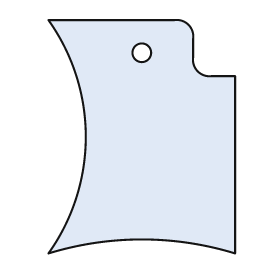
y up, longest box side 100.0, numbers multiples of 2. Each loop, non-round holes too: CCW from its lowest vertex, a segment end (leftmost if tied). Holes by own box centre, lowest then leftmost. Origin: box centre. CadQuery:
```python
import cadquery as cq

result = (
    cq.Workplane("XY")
    .moveTo(-40.0, -50.0)
    .threePointArc((0.0, -44.0), (40.0, -50.0))
    .lineTo(40.0, 26.0)
    .lineTo(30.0, 26.0)
    .threePointArc((24.0, 28.0), (22.0, 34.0))
    .lineTo(22.0, 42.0)
    .threePointArc((20.0, 48.0), (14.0, 50.0))
    .lineTo(-40.0, 50.0)
    .threePointArc((-24.0, 0.0), (-40.0, -50.0))
    .close()
    .moveTo(0.0, 36.0)
    .circle(4.0)
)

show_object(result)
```